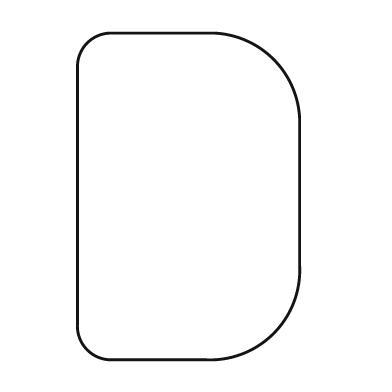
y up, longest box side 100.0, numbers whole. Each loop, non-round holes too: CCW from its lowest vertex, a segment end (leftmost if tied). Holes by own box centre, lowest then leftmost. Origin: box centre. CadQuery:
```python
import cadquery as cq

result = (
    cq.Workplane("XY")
    .moveTo(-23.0, -50.0)
    .lineTo(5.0, -50.0)
    .threePointArc((26.0, -42.0), (34.0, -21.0))
    .lineTo(34.0, 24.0)
    .threePointArc((26.0, 42.0), (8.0, 50.0))
    .lineTo(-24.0, 50.0)
    .threePointArc((-31.0, 47.0), (-34.0, 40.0))
    .lineTo(-34.0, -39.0)
    .threePointArc((-31.0, -47.0), (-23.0, -50.0))
    .close()
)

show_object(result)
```